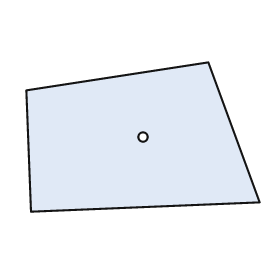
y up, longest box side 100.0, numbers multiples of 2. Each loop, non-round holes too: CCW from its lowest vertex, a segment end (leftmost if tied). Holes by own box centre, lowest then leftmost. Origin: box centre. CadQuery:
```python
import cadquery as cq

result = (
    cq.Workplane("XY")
    .moveTo(-48.0, -32.0)
    .lineTo(50.0, -28.0)
    .lineTo(28.0, 32.0)
    .lineTo(-50.0, 20.0)
    .close()
    .moveTo(0.0, 0.0)
    .circle(2.0)
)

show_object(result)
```